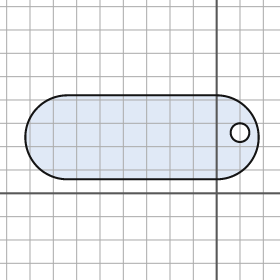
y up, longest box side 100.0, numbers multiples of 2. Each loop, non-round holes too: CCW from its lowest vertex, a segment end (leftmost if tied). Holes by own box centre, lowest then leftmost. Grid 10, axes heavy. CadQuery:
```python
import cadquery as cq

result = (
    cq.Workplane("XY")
    .moveTo(-64.0, 6.0)
    .lineTo(0.0, 6.0)
    .threePointArc((18.0, 24.0), (0.0, 42.0))
    .lineTo(-64.0, 42.0)
    .threePointArc((-82.0, 24.0), (-64.0, 6.0))
    .close()
    .moveTo(10.0, 26.0)
    .circle(4.0)
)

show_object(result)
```